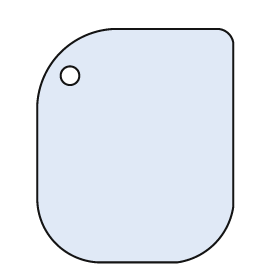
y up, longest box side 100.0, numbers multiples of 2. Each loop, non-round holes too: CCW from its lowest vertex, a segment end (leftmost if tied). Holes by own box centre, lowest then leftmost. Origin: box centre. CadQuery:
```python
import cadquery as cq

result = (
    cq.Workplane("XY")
    .moveTo(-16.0, -50.0)
    .lineTo(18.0, -50.0)
    .threePointArc((34.0, -42.0), (42.0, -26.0))
    .lineTo(42.0, 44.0)
    .threePointArc((40.0, 48.0), (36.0, 50.0))
    .lineTo(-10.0, 50.0)
    .threePointArc((-32.0, 40.0), (-42.0, 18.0))
    .lineTo(-42.0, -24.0)
    .threePointArc((-34.0, -42.0), (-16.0, -50.0))
    .close()
    .moveTo(-28.0, 30.0)
    .circle(4.0)
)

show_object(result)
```